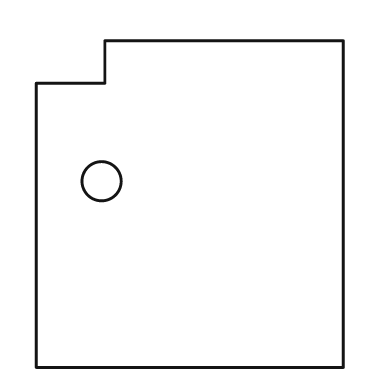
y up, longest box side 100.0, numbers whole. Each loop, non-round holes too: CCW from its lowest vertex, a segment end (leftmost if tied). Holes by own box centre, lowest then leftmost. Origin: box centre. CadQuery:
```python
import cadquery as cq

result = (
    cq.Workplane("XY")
    .moveTo(-47.0, -50.0)
    .lineTo(47.0, -50.0)
    .lineTo(47.0, 50.0)
    .lineTo(-26.0, 50.0)
    .lineTo(-26.0, 37.0)
    .lineTo(-47.0, 37.0)
    .close()
    .moveTo(-27.0, 7.0)
    .circle(6.0)
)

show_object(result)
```